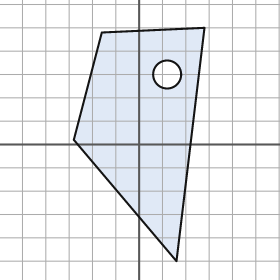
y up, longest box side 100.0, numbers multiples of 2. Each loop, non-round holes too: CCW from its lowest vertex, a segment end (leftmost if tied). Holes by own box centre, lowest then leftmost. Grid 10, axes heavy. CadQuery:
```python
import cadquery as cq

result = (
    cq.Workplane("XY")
    .moveTo(16.0, -50.0)
    .lineTo(28.0, 50.0)
    .lineTo(-16.0, 48.0)
    .lineTo(-28.0, 2.0)
    .close()
    .moveTo(12.0, 30.0)
    .circle(6.0)
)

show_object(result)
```